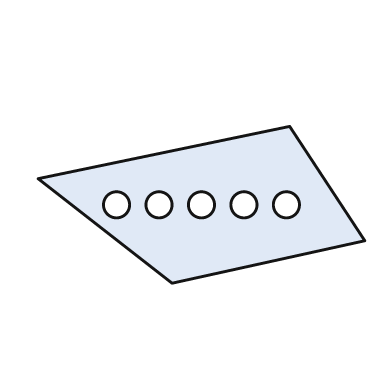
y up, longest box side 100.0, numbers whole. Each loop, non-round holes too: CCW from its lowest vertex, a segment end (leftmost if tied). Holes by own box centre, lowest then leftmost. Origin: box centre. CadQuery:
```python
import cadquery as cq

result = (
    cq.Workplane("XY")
    .moveTo(-9.0, -24.0)
    .lineTo(50.0, -11.0)
    .lineTo(27.0, 24.0)
    .lineTo(-50.0, 8.0)
    .close()
    .moveTo(-26.0, 0.0)
    .circle(4.0)
    .moveTo(-13.0, 0.0)
    .circle(4.0)
    .moveTo(0.0, 0.0)
    .circle(4.0)
    .moveTo(13.0, 0.0)
    .circle(4.0)
    .moveTo(26.0, 0.0)
    .circle(4.0)
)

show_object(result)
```